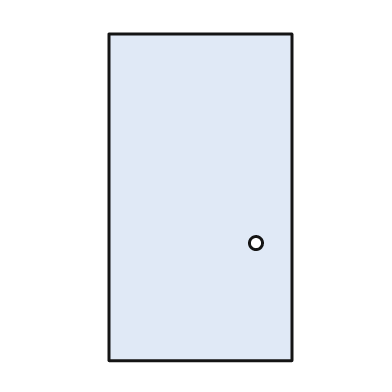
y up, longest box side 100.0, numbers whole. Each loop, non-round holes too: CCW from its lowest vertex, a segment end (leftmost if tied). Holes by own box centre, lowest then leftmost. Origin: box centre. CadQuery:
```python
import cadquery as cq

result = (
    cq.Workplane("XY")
    .moveTo(-28.0, -50.0)
    .lineTo(28.0, -50.0)
    .lineTo(28.0, 50.0)
    .lineTo(-28.0, 50.0)
    .close()
    .moveTo(17.0, -14.0)
    .circle(2.0)
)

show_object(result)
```